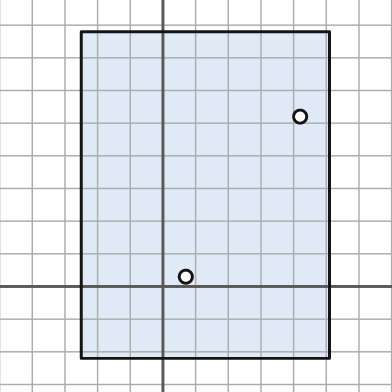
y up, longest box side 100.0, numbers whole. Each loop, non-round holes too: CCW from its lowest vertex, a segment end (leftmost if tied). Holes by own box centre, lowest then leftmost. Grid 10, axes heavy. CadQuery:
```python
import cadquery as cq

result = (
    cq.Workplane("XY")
    .moveTo(-25.0, -22.0)
    .lineTo(51.0, -22.0)
    .lineTo(51.0, 78.0)
    .lineTo(-25.0, 78.0)
    .close()
    .moveTo(7.0, 3.0)
    .circle(2.0)
    .moveTo(42.0, 52.0)
    .circle(2.0)
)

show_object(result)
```